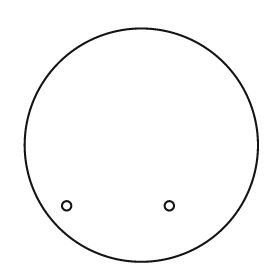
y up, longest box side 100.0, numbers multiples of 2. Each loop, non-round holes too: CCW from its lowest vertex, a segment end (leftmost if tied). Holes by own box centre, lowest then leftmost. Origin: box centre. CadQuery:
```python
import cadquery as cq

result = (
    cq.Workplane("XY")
    .moveTo(0.0, 0.0)
    .circle(50.0)
    .moveTo(-32.0, -26.0)
    .circle(2.0)
    .moveTo(12.0, -26.0)
    .circle(2.0)
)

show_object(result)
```